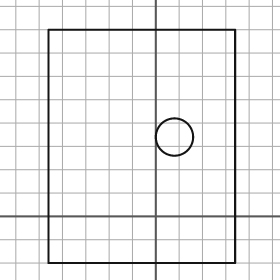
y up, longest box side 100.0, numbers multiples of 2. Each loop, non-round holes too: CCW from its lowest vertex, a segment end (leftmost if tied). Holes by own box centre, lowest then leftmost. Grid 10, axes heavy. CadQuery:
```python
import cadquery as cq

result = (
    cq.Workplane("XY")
    .moveTo(-46.0, -20.0)
    .lineTo(34.0, -20.0)
    .lineTo(34.0, 80.0)
    .lineTo(-46.0, 80.0)
    .close()
    .moveTo(8.0, 34.0)
    .circle(8.0)
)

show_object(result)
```